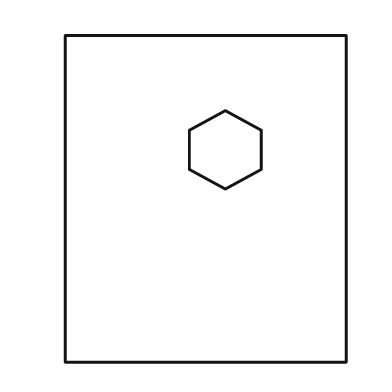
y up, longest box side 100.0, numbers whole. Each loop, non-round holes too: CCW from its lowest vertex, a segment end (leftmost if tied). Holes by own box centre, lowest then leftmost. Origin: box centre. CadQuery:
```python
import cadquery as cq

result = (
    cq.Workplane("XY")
    .moveTo(-43.0, -50.0)
    .lineTo(43.0, -50.0)
    .lineTo(43.0, 50.0)
    .lineTo(-43.0, 50.0)
    .close()
    .moveTo(6.0, 3.0)
    .lineTo(17.0, 9.0)
    .lineTo(17.0, 21.0)
    .lineTo(6.0, 27.0)
    .lineTo(-5.0, 21.0)
    .lineTo(-5.0, 9.0)
    .close()
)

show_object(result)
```